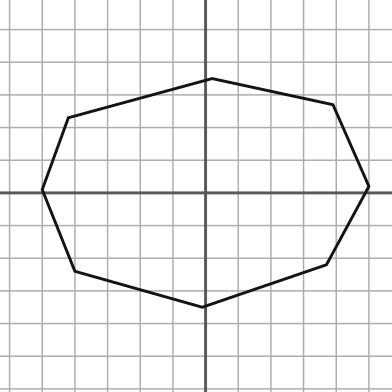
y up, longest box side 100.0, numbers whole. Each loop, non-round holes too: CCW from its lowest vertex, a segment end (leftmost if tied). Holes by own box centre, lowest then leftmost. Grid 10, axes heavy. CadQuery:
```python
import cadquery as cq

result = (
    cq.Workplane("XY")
    .moveTo(-1.0, -35.0)
    .lineTo(37.0, -22.0)
    .lineTo(50.0, 2.0)
    .lineTo(39.0, 27.0)
    .lineTo(2.0, 35.0)
    .lineTo(-42.0, 23.0)
    .lineTo(-50.0, 1.0)
    .lineTo(-40.0, -24.0)
    .close()
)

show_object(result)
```